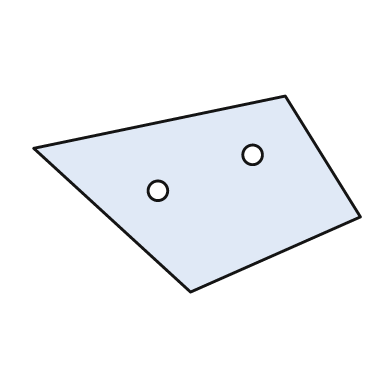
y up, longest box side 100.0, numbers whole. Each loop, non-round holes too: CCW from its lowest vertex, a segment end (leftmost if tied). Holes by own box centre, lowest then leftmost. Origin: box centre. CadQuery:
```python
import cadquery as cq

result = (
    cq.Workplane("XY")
    .moveTo(-2.0, -30.0)
    .lineTo(50.0, -7.0)
    .lineTo(27.0, 30.0)
    .lineTo(-50.0, 14.0)
    .close()
    .moveTo(-12.0, 1.0)
    .circle(3.0)
    .moveTo(17.0, 12.0)
    .circle(3.0)
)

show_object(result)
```